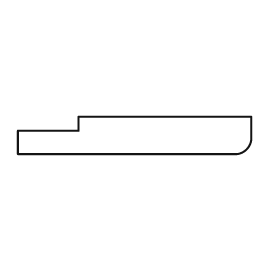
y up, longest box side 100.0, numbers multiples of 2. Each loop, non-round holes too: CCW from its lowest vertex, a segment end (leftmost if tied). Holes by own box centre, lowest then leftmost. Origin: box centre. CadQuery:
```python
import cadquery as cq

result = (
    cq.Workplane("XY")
    .moveTo(-50.0, -8.0)
    .lineTo(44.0, -8.0)
    .threePointArc((48.0, -6.0), (50.0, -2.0))
    .lineTo(50.0, 8.0)
    .lineTo(-24.0, 8.0)
    .lineTo(-24.0, 2.0)
    .lineTo(-50.0, 2.0)
    .close()
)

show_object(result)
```